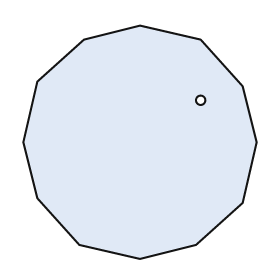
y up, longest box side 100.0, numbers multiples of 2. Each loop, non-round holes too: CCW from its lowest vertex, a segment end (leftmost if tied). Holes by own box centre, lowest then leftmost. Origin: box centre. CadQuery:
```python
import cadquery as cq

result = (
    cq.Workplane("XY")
    .moveTo(0.0, -50.0)
    .lineTo(24.0, -44.0)
    .lineTo(44.0, -26.0)
    .lineTo(50.0, 0.0)
    .lineTo(44.0, 24.0)
    .lineTo(26.0, 44.0)
    .lineTo(0.0, 50.0)
    .lineTo(-24.0, 44.0)
    .lineTo(-44.0, 26.0)
    .lineTo(-50.0, 0.0)
    .lineTo(-44.0, -24.0)
    .lineTo(-26.0, -44.0)
    .close()
    .moveTo(26.0, 18.0)
    .circle(2.0)
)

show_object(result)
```